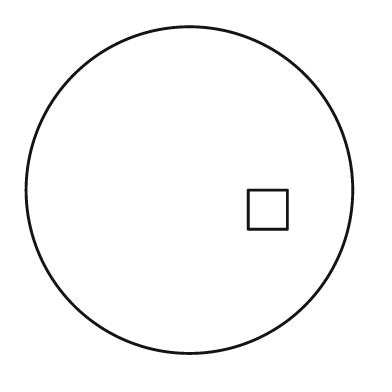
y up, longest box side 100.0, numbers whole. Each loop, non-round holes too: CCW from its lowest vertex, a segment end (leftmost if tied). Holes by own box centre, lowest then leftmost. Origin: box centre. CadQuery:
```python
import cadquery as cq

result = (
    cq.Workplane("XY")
    .moveTo(0.0, 0.0)
    .circle(50.0)
    .moveTo(18.0, -12.0)
    .lineTo(30.0, -12.0)
    .lineTo(30.0, 0.0)
    .lineTo(18.0, 0.0)
    .close()
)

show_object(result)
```